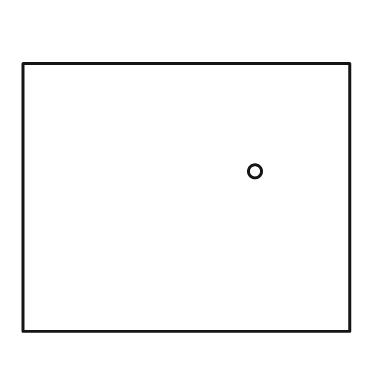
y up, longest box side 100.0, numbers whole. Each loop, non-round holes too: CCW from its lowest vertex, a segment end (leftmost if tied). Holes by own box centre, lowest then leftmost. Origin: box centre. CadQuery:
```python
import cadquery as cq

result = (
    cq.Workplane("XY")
    .moveTo(-50.0, -41.0)
    .lineTo(50.0, -41.0)
    .lineTo(50.0, 41.0)
    .lineTo(-50.0, 41.0)
    .close()
    .moveTo(21.0, 8.0)
    .circle(2.0)
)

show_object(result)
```